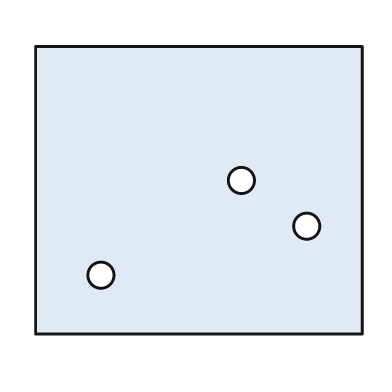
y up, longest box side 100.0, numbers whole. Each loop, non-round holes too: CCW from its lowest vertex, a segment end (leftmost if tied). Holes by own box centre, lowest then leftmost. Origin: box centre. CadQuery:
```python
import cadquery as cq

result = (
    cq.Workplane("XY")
    .moveTo(-50.0, -44.0)
    .lineTo(50.0, -44.0)
    .lineTo(50.0, 44.0)
    .lineTo(-50.0, 44.0)
    .close()
    .moveTo(-30.0, -26.0)
    .circle(4.0)
    .moveTo(33.0, -11.0)
    .circle(4.0)
    .moveTo(13.0, 3.0)
    .circle(4.0)
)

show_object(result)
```